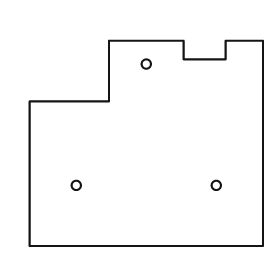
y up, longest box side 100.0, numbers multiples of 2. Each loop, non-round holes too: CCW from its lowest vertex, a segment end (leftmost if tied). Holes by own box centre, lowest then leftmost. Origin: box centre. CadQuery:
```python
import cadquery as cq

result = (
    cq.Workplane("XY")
    .moveTo(-50.0, -44.0)
    .lineTo(50.0, -44.0)
    .lineTo(50.0, 44.0)
    .lineTo(34.0, 44.0)
    .lineTo(34.0, 36.0)
    .lineTo(16.0, 36.0)
    .lineTo(16.0, 44.0)
    .lineTo(-16.0, 44.0)
    .lineTo(-16.0, 18.0)
    .lineTo(-50.0, 18.0)
    .close()
    .moveTo(-30.0, -18.0)
    .circle(2.0)
    .moveTo(30.0, -18.0)
    .circle(2.0)
    .moveTo(0.0, 34.0)
    .circle(2.0)
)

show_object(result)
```